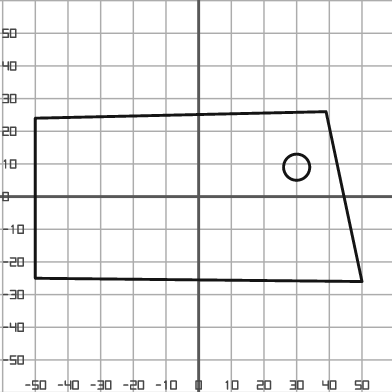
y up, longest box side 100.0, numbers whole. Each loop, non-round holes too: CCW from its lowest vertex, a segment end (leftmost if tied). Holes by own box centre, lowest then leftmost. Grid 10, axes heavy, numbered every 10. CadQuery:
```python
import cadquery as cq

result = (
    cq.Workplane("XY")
    .moveTo(50.0, -26.0)
    .lineTo(39.0, 26.0)
    .lineTo(-50.0, 24.0)
    .lineTo(-50.0, -25.0)
    .close()
    .moveTo(30.0, 9.0)
    .circle(4.0)
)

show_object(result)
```